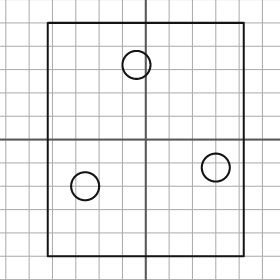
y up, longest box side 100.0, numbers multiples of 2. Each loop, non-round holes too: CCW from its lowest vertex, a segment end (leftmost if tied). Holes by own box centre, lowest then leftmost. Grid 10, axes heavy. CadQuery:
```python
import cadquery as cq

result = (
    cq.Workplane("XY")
    .moveTo(-42.0, -50.0)
    .lineTo(42.0, -50.0)
    .lineTo(42.0, 50.0)
    .lineTo(-42.0, 50.0)
    .close()
    .moveTo(-26.0, -20.0)
    .circle(6.0)
    .moveTo(30.0, -12.0)
    .circle(6.0)
    .moveTo(-4.0, 32.0)
    .circle(6.0)
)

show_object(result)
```